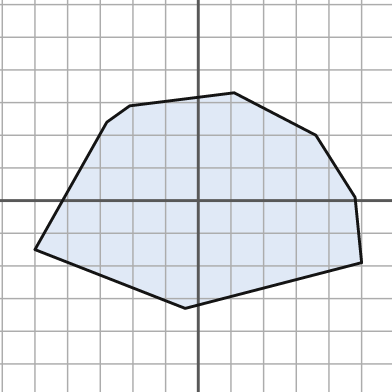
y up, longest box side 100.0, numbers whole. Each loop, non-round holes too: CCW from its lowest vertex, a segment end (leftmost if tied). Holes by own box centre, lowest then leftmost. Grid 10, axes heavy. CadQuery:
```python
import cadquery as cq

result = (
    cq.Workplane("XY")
    .moveTo(-4.0, -33.0)
    .lineTo(50.0, -19.0)
    .lineTo(48.0, 1.0)
    .lineTo(36.0, 20.0)
    .lineTo(11.0, 33.0)
    .lineTo(-21.0, 29.0)
    .lineTo(-28.0, 24.0)
    .lineTo(-50.0, -15.0)
    .close()
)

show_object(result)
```